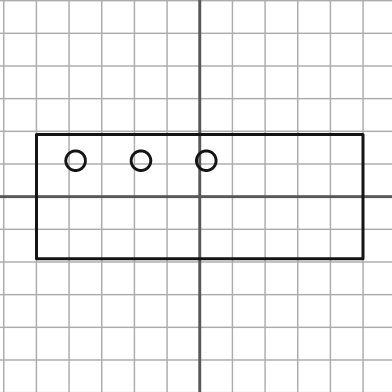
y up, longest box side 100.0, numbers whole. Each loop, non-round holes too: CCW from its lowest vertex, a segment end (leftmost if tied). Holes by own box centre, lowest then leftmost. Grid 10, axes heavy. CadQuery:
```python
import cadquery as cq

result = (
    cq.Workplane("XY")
    .moveTo(-50.0, -19.0)
    .lineTo(50.0, -19.0)
    .lineTo(50.0, 19.0)
    .lineTo(-50.0, 19.0)
    .close()
    .moveTo(-38.0, 11.0)
    .circle(3.0)
    .moveTo(-18.0, 11.0)
    .circle(3.0)
    .moveTo(2.0, 11.0)
    .circle(3.0)
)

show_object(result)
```